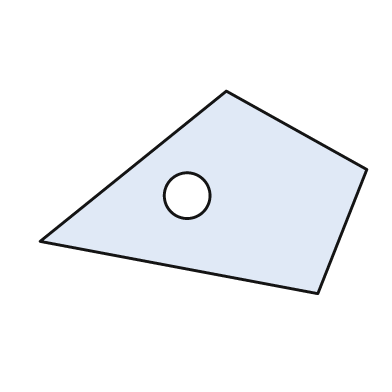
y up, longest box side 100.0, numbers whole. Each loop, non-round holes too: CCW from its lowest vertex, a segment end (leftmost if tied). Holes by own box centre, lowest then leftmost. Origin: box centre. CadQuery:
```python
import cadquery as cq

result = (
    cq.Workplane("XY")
    .moveTo(35.0, -31.0)
    .lineTo(50.0, 7.0)
    .lineTo(7.0, 31.0)
    .lineTo(-50.0, -15.0)
    .close()
    .moveTo(-5.0, -1.0)
    .circle(7.0)
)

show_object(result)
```